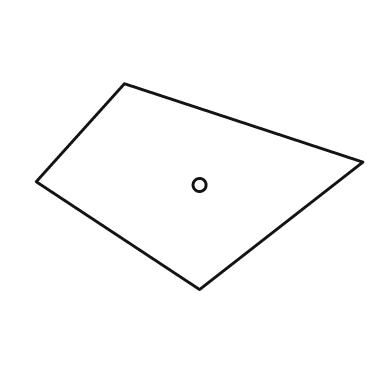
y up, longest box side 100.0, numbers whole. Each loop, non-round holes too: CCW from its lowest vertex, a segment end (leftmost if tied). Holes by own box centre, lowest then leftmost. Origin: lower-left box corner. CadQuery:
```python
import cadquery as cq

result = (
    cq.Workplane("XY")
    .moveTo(50.0, 0.0)
    .lineTo(100.0, 39.0)
    .lineTo(27.0, 63.0)
    .lineTo(0.0, 33.0)
    .close()
    .moveTo(50.0, 32.0)
    .circle(2.0)
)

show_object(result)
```